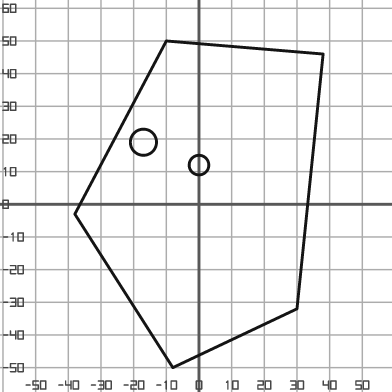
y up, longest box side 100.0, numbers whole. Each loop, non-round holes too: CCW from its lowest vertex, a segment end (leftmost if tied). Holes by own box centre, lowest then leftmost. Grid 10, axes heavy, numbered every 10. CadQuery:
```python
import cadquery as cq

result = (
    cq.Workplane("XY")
    .moveTo(-8.0, -50.0)
    .lineTo(30.0, -32.0)
    .lineTo(38.0, 46.0)
    .lineTo(-10.0, 50.0)
    .lineTo(-38.0, -3.0)
    .close()
    .moveTo(0.0, 12.0)
    .circle(3.0)
    .moveTo(-17.0, 19.0)
    .circle(4.0)
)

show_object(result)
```